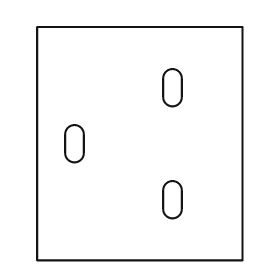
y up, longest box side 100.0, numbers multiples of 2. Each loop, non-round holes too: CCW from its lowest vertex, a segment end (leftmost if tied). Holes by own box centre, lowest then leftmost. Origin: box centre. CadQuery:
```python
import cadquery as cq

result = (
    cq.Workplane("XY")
    .moveTo(-44.0, -50.0)
    .lineTo(44.0, -50.0)
    .lineTo(44.0, 50.0)
    .lineTo(-44.0, 50.0)
    .close()
    .moveTo(10.0, -28.0)
    .threePointArc((14.0, -32.0), (18.0, -28.0))
    .lineTo(18.0, -20.0)
    .threePointArc((14.0, -16.0), (10.0, -20.0))
    .close()
    .moveTo(-32.0, -4.0)
    .threePointArc((-28.0, -8.0), (-24.0, -4.0))
    .lineTo(-24.0, 4.0)
    .threePointArc((-28.0, 8.0), (-32.0, 4.0))
    .close()
    .moveTo(10.0, 20.0)
    .threePointArc((14.0, 16.0), (18.0, 20.0))
    .lineTo(18.0, 28.0)
    .threePointArc((14.0, 32.0), (10.0, 28.0))
    .close()
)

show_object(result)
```